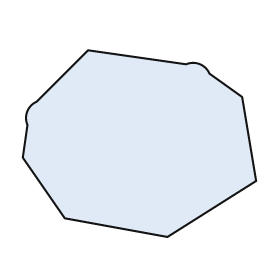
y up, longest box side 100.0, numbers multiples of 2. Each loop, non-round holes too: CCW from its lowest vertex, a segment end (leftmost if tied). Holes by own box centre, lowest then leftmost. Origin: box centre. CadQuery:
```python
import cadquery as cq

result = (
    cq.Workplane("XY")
    .moveTo(12.0, -40.0)
    .lineTo(50.0, -16.0)
    .lineTo(44.0, 20.0)
    .lineTo(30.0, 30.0)
    .threePointArc((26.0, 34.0), (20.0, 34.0))
    .lineTo(-22.0, 40.0)
    .lineTo(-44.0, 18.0)
    .threePointArc((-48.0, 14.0), (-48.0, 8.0))
    .lineTo(-50.0, -6.0)
    .lineTo(-32.0, -32.0)
    .close()
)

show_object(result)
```